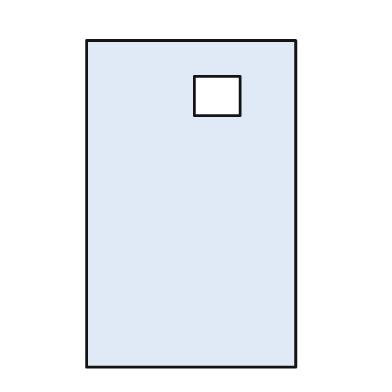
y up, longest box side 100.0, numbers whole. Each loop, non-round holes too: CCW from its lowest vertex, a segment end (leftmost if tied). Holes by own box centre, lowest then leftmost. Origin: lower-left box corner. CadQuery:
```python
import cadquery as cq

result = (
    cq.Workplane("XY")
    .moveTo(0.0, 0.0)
    .lineTo(64.0, 0.0)
    .lineTo(64.0, 100.0)
    .lineTo(0.0, 100.0)
    .close()
    .moveTo(33.0, 77.0)
    .lineTo(47.0, 77.0)
    .lineTo(47.0, 89.0)
    .lineTo(33.0, 89.0)
    .close()
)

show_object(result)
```